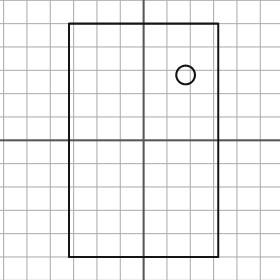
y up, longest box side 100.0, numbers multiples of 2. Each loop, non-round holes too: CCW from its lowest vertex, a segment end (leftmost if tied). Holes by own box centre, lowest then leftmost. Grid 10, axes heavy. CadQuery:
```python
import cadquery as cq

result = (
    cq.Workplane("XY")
    .moveTo(-32.0, -50.0)
    .lineTo(32.0, -50.0)
    .lineTo(32.0, 50.0)
    .lineTo(-32.0, 50.0)
    .close()
    .moveTo(18.0, 28.0)
    .circle(4.0)
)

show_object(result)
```